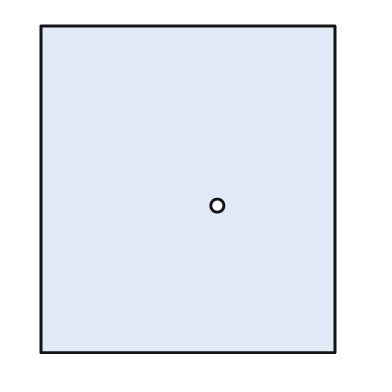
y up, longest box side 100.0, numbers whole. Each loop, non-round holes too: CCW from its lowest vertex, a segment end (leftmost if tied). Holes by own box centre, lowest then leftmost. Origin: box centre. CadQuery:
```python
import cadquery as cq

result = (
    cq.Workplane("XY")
    .moveTo(-45.0, -50.0)
    .lineTo(45.0, -50.0)
    .lineTo(45.0, 50.0)
    .lineTo(-45.0, 50.0)
    .close()
    .moveTo(9.0, -5.0)
    .circle(2.0)
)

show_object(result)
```